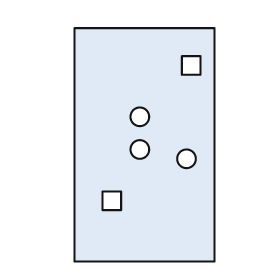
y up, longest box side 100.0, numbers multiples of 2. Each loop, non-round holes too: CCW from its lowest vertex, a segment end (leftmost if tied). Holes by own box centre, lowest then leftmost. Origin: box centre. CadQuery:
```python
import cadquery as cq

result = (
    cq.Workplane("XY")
    .moveTo(-30.0, -50.0)
    .lineTo(30.0, -50.0)
    .lineTo(30.0, 50.0)
    .lineTo(-30.0, 50.0)
    .close()
    .moveTo(-18.0, -28.0)
    .lineTo(-10.0, -28.0)
    .lineTo(-10.0, -20.0)
    .lineTo(-18.0, -20.0)
    .close()
    .moveTo(18.0, -6.0)
    .circle(4.0)
    .moveTo(-2.0, -2.0)
    .circle(4.0)
    .moveTo(-2.0, 12.0)
    .circle(4.0)
    .moveTo(16.0, 30.0)
    .lineTo(24.0, 30.0)
    .lineTo(24.0, 38.0)
    .lineTo(16.0, 38.0)
    .close()
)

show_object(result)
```